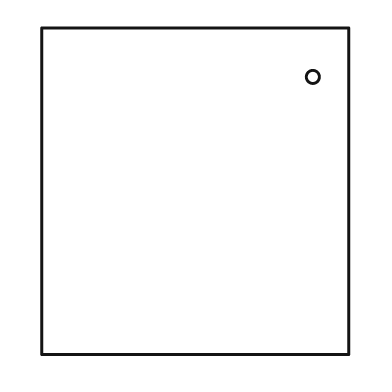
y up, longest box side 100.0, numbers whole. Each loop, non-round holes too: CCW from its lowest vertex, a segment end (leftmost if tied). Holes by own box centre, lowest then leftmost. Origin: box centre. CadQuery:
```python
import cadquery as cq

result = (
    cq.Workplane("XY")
    .moveTo(-47.0, -50.0)
    .lineTo(47.0, -50.0)
    .lineTo(47.0, 50.0)
    .lineTo(-47.0, 50.0)
    .close()
    .moveTo(36.0, 35.0)
    .circle(2.0)
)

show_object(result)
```